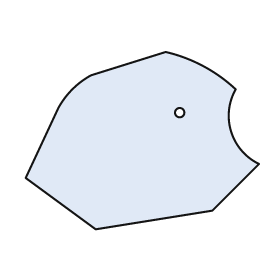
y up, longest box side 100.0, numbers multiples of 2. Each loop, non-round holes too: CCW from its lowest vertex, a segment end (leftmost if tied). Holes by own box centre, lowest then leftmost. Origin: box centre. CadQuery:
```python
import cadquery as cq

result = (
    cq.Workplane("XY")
    .moveTo(-20.0, -38.0)
    .lineTo(30.0, -30.0)
    .lineTo(50.0, -10.0)
    .threePointArc((38.0, 4.0), (40.0, 22.0))
    .threePointArc((26.0, 32.0), (10.0, 38.0))
    .lineTo(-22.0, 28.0)
    .threePointArc((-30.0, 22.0), (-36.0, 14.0))
    .lineTo(-50.0, -16.0)
    .close()
    .moveTo(16.0, 12.0)
    .circle(2.0)
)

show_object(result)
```